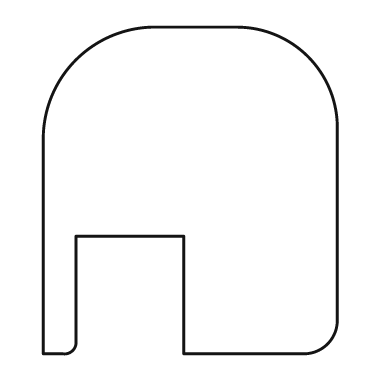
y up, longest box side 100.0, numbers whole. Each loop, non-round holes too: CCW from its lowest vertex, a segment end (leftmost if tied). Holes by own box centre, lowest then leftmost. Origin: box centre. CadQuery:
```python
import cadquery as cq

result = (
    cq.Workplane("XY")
    .moveTo(-45.0, -50.0)
    .lineTo(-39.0, -50.0)
    .threePointArc((-36.0, -49.0), (-35.0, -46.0))
    .lineTo(-35.0, -14.0)
    .lineTo(-2.0, -14.0)
    .lineTo(-2.0, -50.0)
    .lineTo(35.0, -50.0)
    .threePointArc((42.0, -47.0), (45.0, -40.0))
    .lineTo(45.0, 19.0)
    .threePointArc((36.0, 41.0), (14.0, 50.0))
    .lineTo(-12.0, 50.0)
    .threePointArc((-35.0, 40.0), (-45.0, 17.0))
    .close()
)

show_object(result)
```